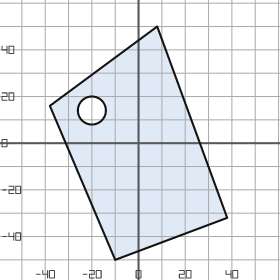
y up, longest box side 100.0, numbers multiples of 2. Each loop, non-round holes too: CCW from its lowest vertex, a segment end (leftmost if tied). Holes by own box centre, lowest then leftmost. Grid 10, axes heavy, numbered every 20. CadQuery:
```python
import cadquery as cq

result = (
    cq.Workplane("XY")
    .moveTo(-10.0, -50.0)
    .lineTo(38.0, -32.0)
    .lineTo(8.0, 50.0)
    .lineTo(-38.0, 16.0)
    .close()
    .moveTo(-20.0, 14.0)
    .circle(6.0)
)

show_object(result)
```